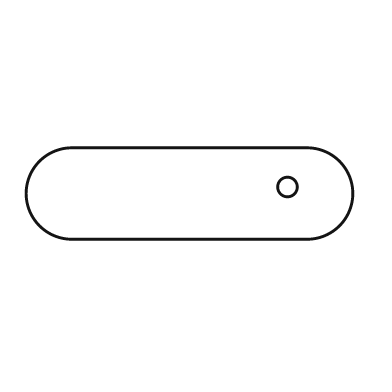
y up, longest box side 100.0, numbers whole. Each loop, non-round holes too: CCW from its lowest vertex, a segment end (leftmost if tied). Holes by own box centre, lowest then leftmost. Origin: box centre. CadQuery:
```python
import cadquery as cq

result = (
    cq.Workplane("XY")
    .moveTo(-36.0, -14.0)
    .lineTo(36.0, -14.0)
    .threePointArc((50.0, 0.0), (36.0, 14.0))
    .lineTo(-36.0, 14.0)
    .threePointArc((-50.0, 0.0), (-36.0, -14.0))
    .close()
    .moveTo(30.0, 2.0)
    .circle(3.0)
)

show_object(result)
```